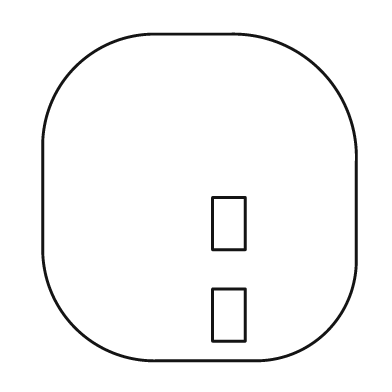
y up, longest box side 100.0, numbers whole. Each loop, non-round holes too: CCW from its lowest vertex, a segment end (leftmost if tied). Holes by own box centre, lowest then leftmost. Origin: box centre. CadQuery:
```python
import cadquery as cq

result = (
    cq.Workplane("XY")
    .moveTo(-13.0, -50.0)
    .lineTo(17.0, -50.0)
    .threePointArc((39.0, -41.0), (48.0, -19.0))
    .lineTo(48.0, 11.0)
    .threePointArc((37.0, 39.0), (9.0, 50.0))
    .lineTo(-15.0, 50.0)
    .threePointArc((-38.0, 40.0), (-48.0, 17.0))
    .lineTo(-48.0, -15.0)
    .threePointArc((-38.0, -40.0), (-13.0, -50.0))
    .close()
    .moveTo(4.0, -44.0)
    .lineTo(14.0, -44.0)
    .lineTo(14.0, -28.0)
    .lineTo(4.0, -28.0)
    .close()
    .moveTo(4.0, -16.0)
    .lineTo(14.0, -16.0)
    .lineTo(14.0, 0.0)
    .lineTo(4.0, 0.0)
    .close()
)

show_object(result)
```